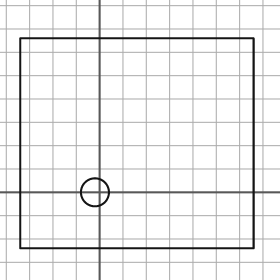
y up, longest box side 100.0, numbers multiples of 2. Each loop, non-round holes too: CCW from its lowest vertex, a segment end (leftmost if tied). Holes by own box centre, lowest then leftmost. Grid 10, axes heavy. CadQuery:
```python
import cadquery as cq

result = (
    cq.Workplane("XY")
    .moveTo(-34.0, -24.0)
    .lineTo(66.0, -24.0)
    .lineTo(66.0, 66.0)
    .lineTo(-34.0, 66.0)
    .close()
    .moveTo(-2.0, 0.0)
    .circle(6.0)
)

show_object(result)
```